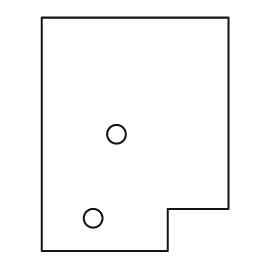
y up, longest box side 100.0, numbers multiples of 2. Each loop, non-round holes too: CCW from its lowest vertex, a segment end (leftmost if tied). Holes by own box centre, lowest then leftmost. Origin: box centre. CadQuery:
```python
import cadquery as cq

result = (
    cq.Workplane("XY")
    .moveTo(-40.0, -50.0)
    .lineTo(14.0, -50.0)
    .lineTo(14.0, -32.0)
    .lineTo(40.0, -32.0)
    .lineTo(40.0, 50.0)
    .lineTo(-40.0, 50.0)
    .close()
    .moveTo(-18.0, -36.0)
    .circle(4.0)
    .moveTo(-8.0, 0.0)
    .circle(4.0)
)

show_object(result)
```